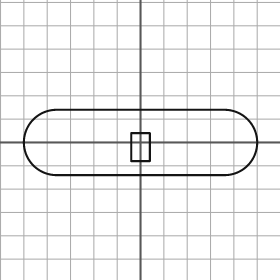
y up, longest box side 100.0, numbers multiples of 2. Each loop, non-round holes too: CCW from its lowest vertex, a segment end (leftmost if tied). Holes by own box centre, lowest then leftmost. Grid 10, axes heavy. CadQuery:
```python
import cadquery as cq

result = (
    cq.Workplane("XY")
    .moveTo(-36.0, -14.0)
    .lineTo(36.0, -14.0)
    .threePointArc((50.0, 0.0), (36.0, 14.0))
    .lineTo(-36.0, 14.0)
    .threePointArc((-50.0, 0.0), (-36.0, -14.0))
    .close()
    .moveTo(-4.0, -8.0)
    .lineTo(4.0, -8.0)
    .lineTo(4.0, 4.0)
    .lineTo(-4.0, 4.0)
    .close()
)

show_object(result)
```